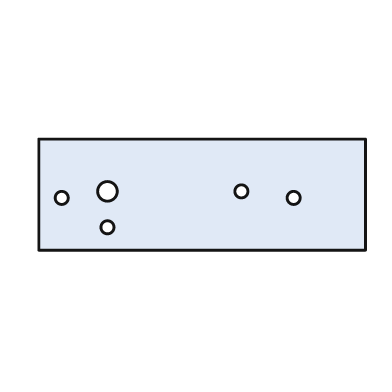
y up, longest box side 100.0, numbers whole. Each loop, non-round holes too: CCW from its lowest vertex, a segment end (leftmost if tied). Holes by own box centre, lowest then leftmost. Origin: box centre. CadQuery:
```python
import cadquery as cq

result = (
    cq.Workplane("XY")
    .moveTo(-50.0, -17.0)
    .lineTo(50.0, -17.0)
    .lineTo(50.0, 17.0)
    .lineTo(-50.0, 17.0)
    .close()
    .moveTo(-29.0, -10.0)
    .circle(2.0)
    .moveTo(-43.0, -1.0)
    .circle(2.0)
    .moveTo(28.0, -1.0)
    .circle(2.0)
    .moveTo(-29.0, 1.0)
    .circle(3.0)
    .moveTo(12.0, 1.0)
    .circle(2.0)
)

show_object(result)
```